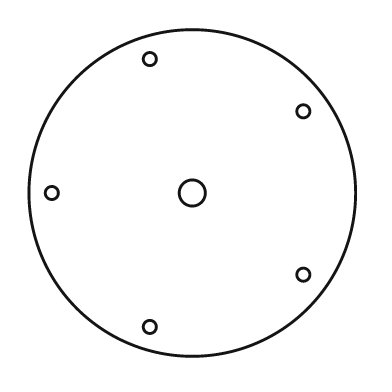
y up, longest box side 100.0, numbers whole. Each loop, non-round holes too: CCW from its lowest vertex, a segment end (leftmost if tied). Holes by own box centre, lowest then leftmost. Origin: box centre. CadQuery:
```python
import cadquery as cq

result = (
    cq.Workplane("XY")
    .moveTo(0.0, 0.0)
    .circle(50.0)
    .moveTo(-13.0, -41.0)
    .circle(2.0)
    .moveTo(34.0, -25.0)
    .circle(2.0)
    .moveTo(-43.0, 0.0)
    .circle(2.0)
    .moveTo(0.0, 0.0)
    .circle(4.0)
    .moveTo(34.0, 25.0)
    .circle(2.0)
    .moveTo(-13.0, 41.0)
    .circle(2.0)
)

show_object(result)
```